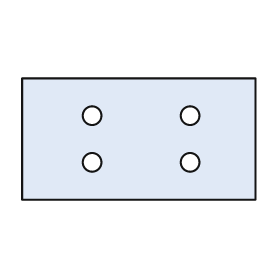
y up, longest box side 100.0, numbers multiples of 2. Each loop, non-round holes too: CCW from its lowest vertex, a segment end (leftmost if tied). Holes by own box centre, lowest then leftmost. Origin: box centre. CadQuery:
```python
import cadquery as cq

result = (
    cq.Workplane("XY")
    .moveTo(-50.0, -26.0)
    .lineTo(50.0, -26.0)
    .lineTo(50.0, 26.0)
    .lineTo(-50.0, 26.0)
    .close()
    .moveTo(-20.0, -10.0)
    .circle(4.0)
    .moveTo(22.0, -10.0)
    .circle(4.0)
    .moveTo(-20.0, 10.0)
    .circle(4.0)
    .moveTo(22.0, 10.0)
    .circle(4.0)
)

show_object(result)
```